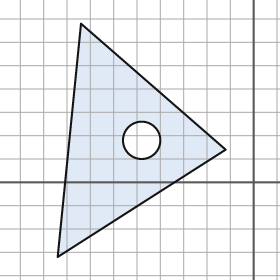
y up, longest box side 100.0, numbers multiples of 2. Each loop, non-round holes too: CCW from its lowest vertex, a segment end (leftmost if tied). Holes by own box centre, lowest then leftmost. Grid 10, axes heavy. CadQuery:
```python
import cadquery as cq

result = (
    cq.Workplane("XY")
    .moveTo(-84.0, -32.0)
    .lineTo(-12.0, 14.0)
    .lineTo(-74.0, 68.0)
    .close()
    .moveTo(-48.0, 18.0)
    .circle(8.0)
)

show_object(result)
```